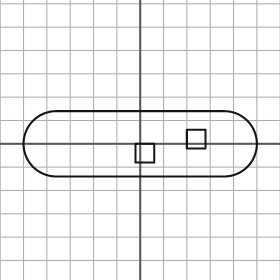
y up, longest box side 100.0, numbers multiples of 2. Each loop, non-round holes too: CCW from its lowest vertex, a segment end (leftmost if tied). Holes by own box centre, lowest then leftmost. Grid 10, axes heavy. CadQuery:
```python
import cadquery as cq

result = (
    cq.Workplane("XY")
    .moveTo(-36.0, -14.0)
    .lineTo(36.0, -14.0)
    .threePointArc((50.0, 0.0), (36.0, 14.0))
    .lineTo(-36.0, 14.0)
    .threePointArc((-50.0, 0.0), (-36.0, -14.0))
    .close()
    .moveTo(-2.0, -8.0)
    .lineTo(6.0, -8.0)
    .lineTo(6.0, 0.0)
    .lineTo(-2.0, 0.0)
    .close()
    .moveTo(20.0, -2.0)
    .lineTo(28.0, -2.0)
    .lineTo(28.0, 6.0)
    .lineTo(20.0, 6.0)
    .close()
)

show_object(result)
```